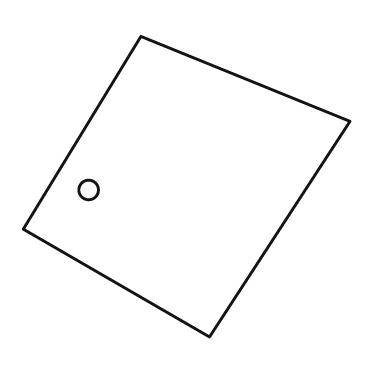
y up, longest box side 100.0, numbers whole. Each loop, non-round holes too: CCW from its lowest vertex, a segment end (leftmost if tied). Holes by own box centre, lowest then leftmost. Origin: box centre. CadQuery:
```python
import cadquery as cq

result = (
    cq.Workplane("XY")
    .moveTo(7.0, -46.0)
    .lineTo(50.0, 20.0)
    .lineTo(-14.0, 46.0)
    .lineTo(-50.0, -13.0)
    .close()
    .moveTo(-30.0, -1.0)
    .circle(3.0)
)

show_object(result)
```